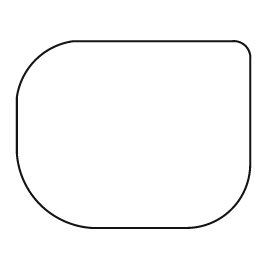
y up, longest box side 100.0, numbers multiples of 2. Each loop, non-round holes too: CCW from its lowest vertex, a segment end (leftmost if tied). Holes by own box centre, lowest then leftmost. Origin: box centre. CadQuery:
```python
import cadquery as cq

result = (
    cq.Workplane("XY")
    .moveTo(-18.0, -40.0)
    .lineTo(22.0, -40.0)
    .threePointArc((42.0, -32.0), (50.0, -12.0))
    .lineTo(50.0, 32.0)
    .threePointArc((48.0, 38.0), (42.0, 40.0))
    .lineTo(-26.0, 40.0)
    .threePointArc((-42.0, 32.0), (-50.0, 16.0))
    .lineTo(-50.0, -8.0)
    .threePointArc((-40.0, -30.0), (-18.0, -40.0))
    .close()
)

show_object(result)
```